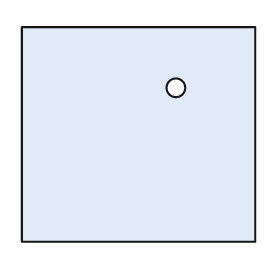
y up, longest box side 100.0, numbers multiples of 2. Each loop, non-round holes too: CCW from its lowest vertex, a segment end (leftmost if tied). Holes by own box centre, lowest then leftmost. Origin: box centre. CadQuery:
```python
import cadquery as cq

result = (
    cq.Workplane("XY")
    .moveTo(-50.0, -46.0)
    .lineTo(50.0, -46.0)
    .lineTo(50.0, 46.0)
    .lineTo(-50.0, 46.0)
    .close()
    .moveTo(16.0, 20.0)
    .circle(4.0)
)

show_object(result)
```